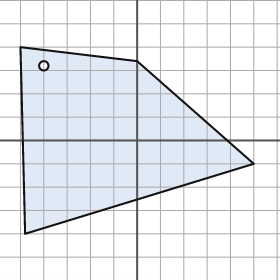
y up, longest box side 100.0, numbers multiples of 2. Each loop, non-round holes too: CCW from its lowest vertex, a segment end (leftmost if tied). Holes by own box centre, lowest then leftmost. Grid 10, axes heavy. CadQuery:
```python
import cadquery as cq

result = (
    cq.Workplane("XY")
    .moveTo(-48.0, -40.0)
    .lineTo(50.0, -10.0)
    .lineTo(0.0, 34.0)
    .lineTo(-50.0, 40.0)
    .close()
    .moveTo(-40.0, 32.0)
    .circle(2.0)
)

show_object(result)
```